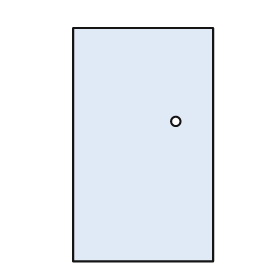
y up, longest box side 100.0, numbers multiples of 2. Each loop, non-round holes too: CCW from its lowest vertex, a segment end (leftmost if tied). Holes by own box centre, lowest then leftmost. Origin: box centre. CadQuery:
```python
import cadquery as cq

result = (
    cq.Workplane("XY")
    .moveTo(-30.0, -50.0)
    .lineTo(30.0, -50.0)
    .lineTo(30.0, 50.0)
    .lineTo(-30.0, 50.0)
    .close()
    .moveTo(14.0, 10.0)
    .circle(2.0)
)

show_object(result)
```